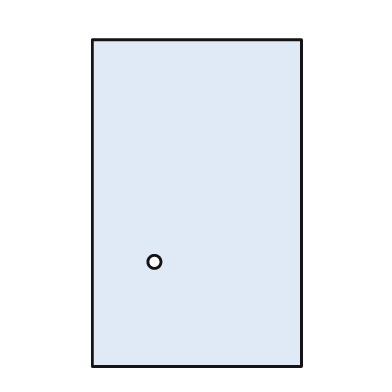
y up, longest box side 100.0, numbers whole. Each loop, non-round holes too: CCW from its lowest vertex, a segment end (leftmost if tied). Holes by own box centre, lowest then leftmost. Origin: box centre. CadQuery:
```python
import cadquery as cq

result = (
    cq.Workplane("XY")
    .moveTo(-32.0, -50.0)
    .lineTo(32.0, -50.0)
    .lineTo(32.0, 50.0)
    .lineTo(-32.0, 50.0)
    .close()
    .moveTo(-13.0, -18.0)
    .circle(2.0)
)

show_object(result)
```